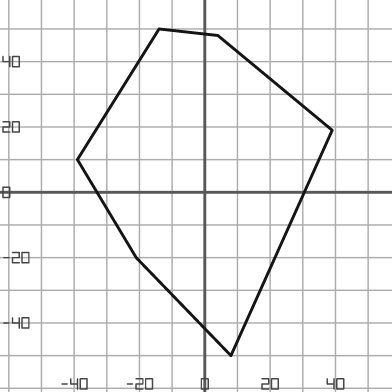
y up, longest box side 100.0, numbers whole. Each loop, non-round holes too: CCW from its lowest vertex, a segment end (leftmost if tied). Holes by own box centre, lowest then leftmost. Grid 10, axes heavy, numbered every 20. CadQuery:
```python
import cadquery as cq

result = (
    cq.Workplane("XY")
    .moveTo(8.0, -50.0)
    .lineTo(39.0, 19.0)
    .lineTo(4.0, 48.0)
    .lineTo(-14.0, 50.0)
    .lineTo(-39.0, 10.0)
    .lineTo(-21.0, -20.0)
    .close()
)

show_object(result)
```